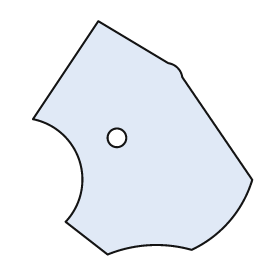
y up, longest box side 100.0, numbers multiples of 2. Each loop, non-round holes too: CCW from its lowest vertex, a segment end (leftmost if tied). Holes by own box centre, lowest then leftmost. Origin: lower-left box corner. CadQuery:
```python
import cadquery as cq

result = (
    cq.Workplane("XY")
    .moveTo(32.0, 0.0)
    .threePointArc((50.0, 4.0), (68.0, 2.0))
    .threePointArc((84.0, 14.0), (94.0, 32.0))
    .lineTo(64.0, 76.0)
    .threePointArc((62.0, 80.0), (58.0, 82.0))
    .lineTo(28.0, 100.0)
    .lineTo(0.0, 58.0)
    .threePointArc((20.0, 40.0), (14.0, 14.0))
    .close()
    .moveTo(36.0, 50.0)
    .circle(4.0)
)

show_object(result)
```